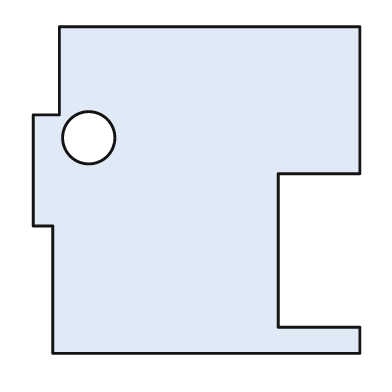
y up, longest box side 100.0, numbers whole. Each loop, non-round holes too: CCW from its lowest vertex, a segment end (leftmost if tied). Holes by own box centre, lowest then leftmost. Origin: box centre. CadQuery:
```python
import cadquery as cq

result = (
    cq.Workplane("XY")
    .moveTo(-44.0, -50.0)
    .lineTo(50.0, -50.0)
    .lineTo(50.0, -42.0)
    .lineTo(25.0, -42.0)
    .lineTo(25.0, 5.0)
    .lineTo(50.0, 5.0)
    .lineTo(50.0, 50.0)
    .lineTo(-42.0, 50.0)
    .lineTo(-42.0, 23.0)
    .lineTo(-50.0, 23.0)
    .lineTo(-50.0, -11.0)
    .lineTo(-44.0, -11.0)
    .close()
    .moveTo(-33.0, 16.0)
    .circle(8.0)
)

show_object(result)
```